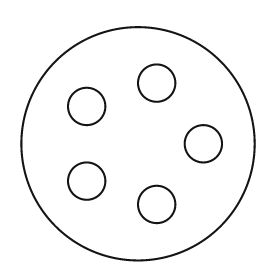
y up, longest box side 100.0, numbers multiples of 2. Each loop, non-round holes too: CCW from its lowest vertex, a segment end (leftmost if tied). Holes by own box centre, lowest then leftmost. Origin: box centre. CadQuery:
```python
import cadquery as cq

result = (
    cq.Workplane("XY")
    .moveTo(0.0, 0.0)
    .circle(50.0)
    .moveTo(8.0, -26.0)
    .circle(8.0)
    .moveTo(-22.0, -16.0)
    .circle(8.0)
    .moveTo(28.0, 0.0)
    .circle(8.0)
    .moveTo(-22.0, 16.0)
    .circle(8.0)
    .moveTo(8.0, 26.0)
    .circle(8.0)
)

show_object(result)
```